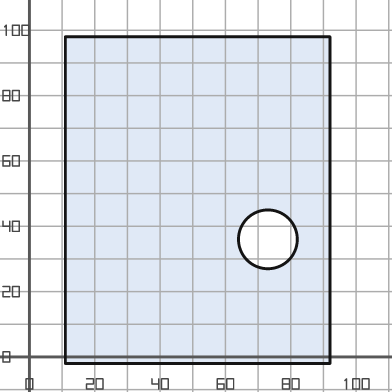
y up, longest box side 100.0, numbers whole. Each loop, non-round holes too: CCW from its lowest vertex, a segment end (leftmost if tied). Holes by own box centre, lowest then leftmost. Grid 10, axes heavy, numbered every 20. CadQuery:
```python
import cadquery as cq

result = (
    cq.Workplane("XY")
    .moveTo(11.0, -2.0)
    .lineTo(92.0, -2.0)
    .lineTo(92.0, 98.0)
    .lineTo(11.0, 98.0)
    .close()
    .moveTo(73.0, 36.0)
    .circle(9.0)
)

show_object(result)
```